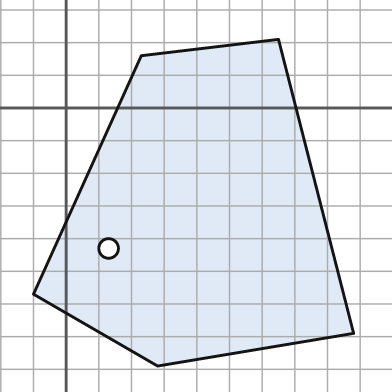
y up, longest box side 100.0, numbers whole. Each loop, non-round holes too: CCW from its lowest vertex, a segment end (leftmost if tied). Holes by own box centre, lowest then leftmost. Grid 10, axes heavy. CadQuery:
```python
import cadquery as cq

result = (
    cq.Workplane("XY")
    .moveTo(28.0, -79.0)
    .lineTo(88.0, -69.0)
    .lineTo(65.0, 21.0)
    .lineTo(23.0, 16.0)
    .lineTo(-10.0, -57.0)
    .close()
    .moveTo(13.0, -43.0)
    .circle(3.0)
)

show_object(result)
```